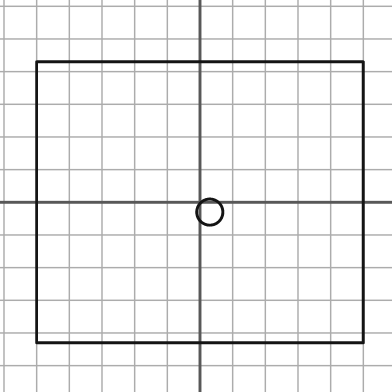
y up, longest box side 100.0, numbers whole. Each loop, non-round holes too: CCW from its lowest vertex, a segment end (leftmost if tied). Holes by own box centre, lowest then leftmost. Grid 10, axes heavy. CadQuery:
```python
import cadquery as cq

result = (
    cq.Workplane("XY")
    .moveTo(-50.0, -43.0)
    .lineTo(50.0, -43.0)
    .lineTo(50.0, 43.0)
    .lineTo(-50.0, 43.0)
    .close()
    .moveTo(3.0, -3.0)
    .circle(4.0)
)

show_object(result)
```